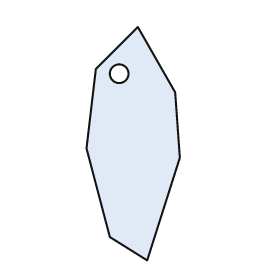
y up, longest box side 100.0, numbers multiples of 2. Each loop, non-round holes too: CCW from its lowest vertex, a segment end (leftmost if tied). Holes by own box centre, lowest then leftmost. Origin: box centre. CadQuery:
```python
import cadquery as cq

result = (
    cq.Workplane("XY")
    .moveTo(6.0, -50.0)
    .lineTo(20.0, -6.0)
    .lineTo(18.0, 22.0)
    .lineTo(2.0, 50.0)
    .lineTo(-16.0, 32.0)
    .lineTo(-20.0, -2.0)
    .lineTo(-10.0, -40.0)
    .close()
    .moveTo(-6.0, 30.0)
    .circle(4.0)
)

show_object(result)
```